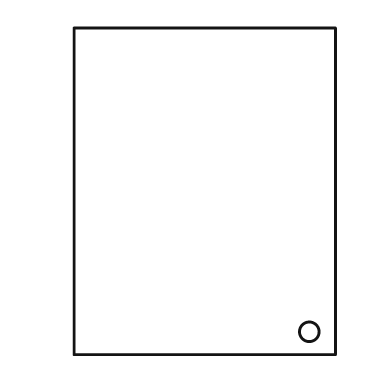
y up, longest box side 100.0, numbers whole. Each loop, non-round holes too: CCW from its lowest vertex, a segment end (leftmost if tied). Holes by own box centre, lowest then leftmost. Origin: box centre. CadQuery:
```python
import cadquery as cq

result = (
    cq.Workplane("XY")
    .moveTo(-40.0, -50.0)
    .lineTo(40.0, -50.0)
    .lineTo(40.0, 50.0)
    .lineTo(-40.0, 50.0)
    .close()
    .moveTo(32.0, -43.0)
    .circle(3.0)
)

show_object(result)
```